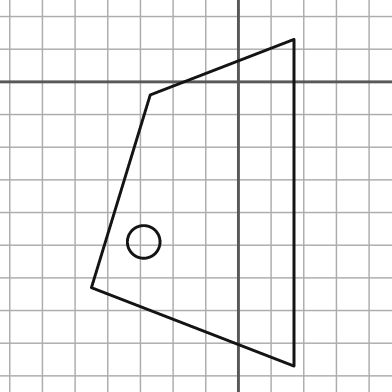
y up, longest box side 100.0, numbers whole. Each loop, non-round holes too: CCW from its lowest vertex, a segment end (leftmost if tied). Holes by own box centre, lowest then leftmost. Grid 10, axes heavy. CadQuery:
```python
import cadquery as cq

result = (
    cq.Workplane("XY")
    .moveTo(17.0, -87.0)
    .lineTo(17.0, 13.0)
    .lineTo(-27.0, -4.0)
    .lineTo(-45.0, -63.0)
    .close()
    .moveTo(-29.0, -49.0)
    .circle(5.0)
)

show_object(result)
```